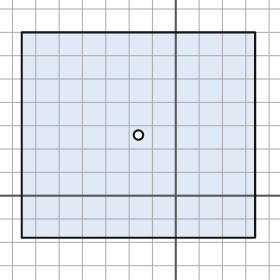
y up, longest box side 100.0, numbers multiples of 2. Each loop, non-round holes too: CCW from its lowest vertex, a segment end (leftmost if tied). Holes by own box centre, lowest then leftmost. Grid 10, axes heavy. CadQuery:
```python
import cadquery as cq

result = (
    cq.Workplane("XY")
    .moveTo(-66.0, -18.0)
    .lineTo(34.0, -18.0)
    .lineTo(34.0, 70.0)
    .lineTo(-66.0, 70.0)
    .close()
    .moveTo(-16.0, 26.0)
    .circle(2.0)
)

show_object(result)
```